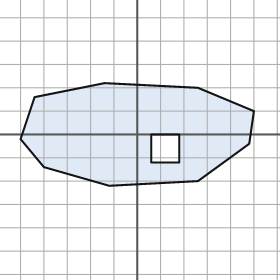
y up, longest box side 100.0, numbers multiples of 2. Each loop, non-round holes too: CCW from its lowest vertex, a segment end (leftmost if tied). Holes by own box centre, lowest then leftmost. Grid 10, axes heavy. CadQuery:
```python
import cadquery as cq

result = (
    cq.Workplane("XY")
    .moveTo(-12.0, -22.0)
    .lineTo(26.0, -20.0)
    .lineTo(48.0, -4.0)
    .lineTo(50.0, 10.0)
    .lineTo(26.0, 20.0)
    .lineTo(-14.0, 22.0)
    .lineTo(-44.0, 16.0)
    .lineTo(-50.0, -2.0)
    .lineTo(-40.0, -14.0)
    .close()
    .moveTo(6.0, -12.0)
    .lineTo(18.0, -12.0)
    .lineTo(18.0, 0.0)
    .lineTo(6.0, 0.0)
    .close()
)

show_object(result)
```